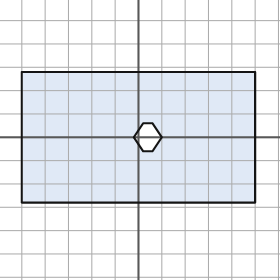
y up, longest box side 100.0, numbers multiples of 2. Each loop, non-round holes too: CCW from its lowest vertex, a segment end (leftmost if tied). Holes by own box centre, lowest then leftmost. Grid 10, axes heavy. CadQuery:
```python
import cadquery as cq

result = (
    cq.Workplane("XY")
    .moveTo(-50.0, -28.0)
    .lineTo(50.0, -28.0)
    .lineTo(50.0, 28.0)
    .lineTo(-50.0, 28.0)
    .close()
    .moveTo(2.0, -6.0)
    .lineTo(6.0, -6.0)
    .lineTo(10.0, 0.0)
    .lineTo(6.0, 6.0)
    .lineTo(2.0, 6.0)
    .lineTo(-2.0, 0.0)
    .close()
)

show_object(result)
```